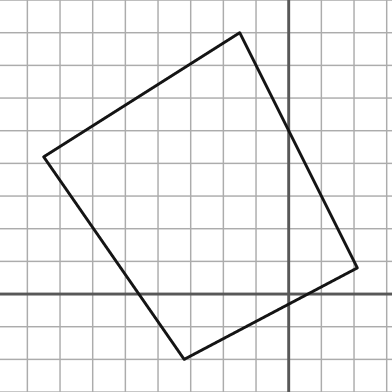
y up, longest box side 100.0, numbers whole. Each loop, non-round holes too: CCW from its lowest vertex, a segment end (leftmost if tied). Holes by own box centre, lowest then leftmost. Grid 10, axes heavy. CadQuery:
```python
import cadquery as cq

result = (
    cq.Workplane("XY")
    .moveTo(-32.0, -20.0)
    .lineTo(21.0, 8.0)
    .lineTo(-15.0, 80.0)
    .lineTo(-75.0, 42.0)
    .close()
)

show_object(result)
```